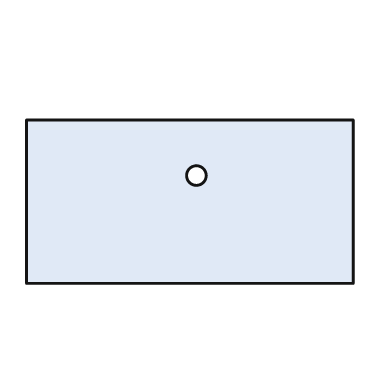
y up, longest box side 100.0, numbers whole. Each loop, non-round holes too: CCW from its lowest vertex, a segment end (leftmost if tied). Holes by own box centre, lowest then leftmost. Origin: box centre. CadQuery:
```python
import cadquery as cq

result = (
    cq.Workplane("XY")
    .moveTo(-50.0, -25.0)
    .lineTo(50.0, -25.0)
    .lineTo(50.0, 25.0)
    .lineTo(-50.0, 25.0)
    .close()
    .moveTo(2.0, 8.0)
    .circle(3.0)
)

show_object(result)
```